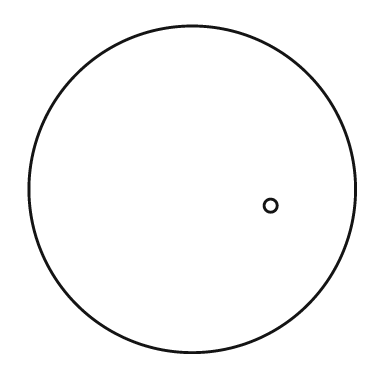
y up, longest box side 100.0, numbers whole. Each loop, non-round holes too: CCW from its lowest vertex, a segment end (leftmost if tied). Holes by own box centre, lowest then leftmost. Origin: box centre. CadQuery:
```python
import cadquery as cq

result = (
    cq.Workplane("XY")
    .moveTo(0.0, 0.0)
    .circle(50.0)
    .moveTo(24.0, -5.0)
    .circle(2.0)
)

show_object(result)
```